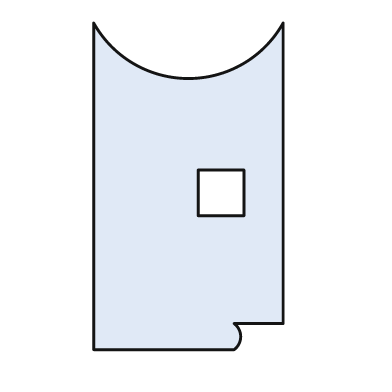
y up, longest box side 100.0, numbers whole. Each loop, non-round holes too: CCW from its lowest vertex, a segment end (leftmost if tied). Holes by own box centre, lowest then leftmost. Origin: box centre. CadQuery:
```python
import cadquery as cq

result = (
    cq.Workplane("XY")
    .moveTo(-29.0, -50.0)
    .lineTo(14.0, -50.0)
    .threePointArc((16.0, -46.0), (14.0, -42.0))
    .lineTo(29.0, -42.0)
    .lineTo(29.0, 50.0)
    .threePointArc((0.0, 33.0), (-29.0, 50.0))
    .close()
    .moveTo(3.0, -9.0)
    .lineTo(17.0, -9.0)
    .lineTo(17.0, 5.0)
    .lineTo(3.0, 5.0)
    .close()
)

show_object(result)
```